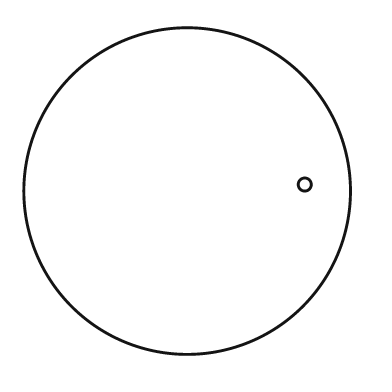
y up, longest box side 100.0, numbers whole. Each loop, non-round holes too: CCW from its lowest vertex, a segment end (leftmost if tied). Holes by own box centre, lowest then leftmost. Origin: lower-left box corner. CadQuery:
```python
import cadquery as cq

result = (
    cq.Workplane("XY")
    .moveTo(50.0, 50.0)
    .circle(50.0)
    .moveTo(86.0, 52.0)
    .circle(2.0)
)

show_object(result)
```